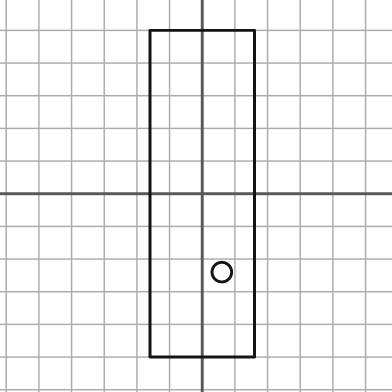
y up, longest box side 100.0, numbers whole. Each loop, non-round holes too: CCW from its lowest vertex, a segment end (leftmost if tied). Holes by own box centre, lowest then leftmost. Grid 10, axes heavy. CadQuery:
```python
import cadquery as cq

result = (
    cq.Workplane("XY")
    .moveTo(-16.0, -50.0)
    .lineTo(16.0, -50.0)
    .lineTo(16.0, 50.0)
    .lineTo(-16.0, 50.0)
    .close()
    .moveTo(6.0, -24.0)
    .circle(3.0)
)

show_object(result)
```